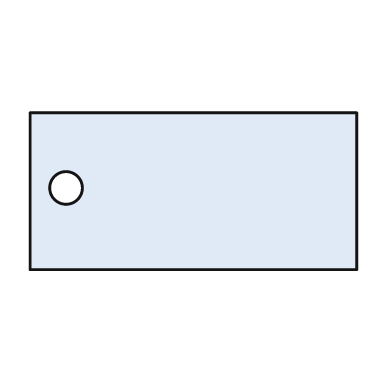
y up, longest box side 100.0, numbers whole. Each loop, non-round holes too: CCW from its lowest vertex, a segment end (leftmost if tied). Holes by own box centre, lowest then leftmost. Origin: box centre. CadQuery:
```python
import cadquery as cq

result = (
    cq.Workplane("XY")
    .moveTo(-50.0, -24.0)
    .lineTo(50.0, -24.0)
    .lineTo(50.0, 24.0)
    .lineTo(-50.0, 24.0)
    .close()
    .moveTo(-39.0, 1.0)
    .circle(5.0)
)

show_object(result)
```